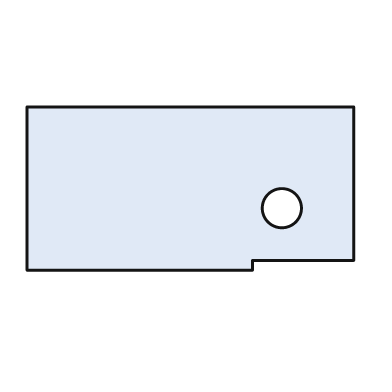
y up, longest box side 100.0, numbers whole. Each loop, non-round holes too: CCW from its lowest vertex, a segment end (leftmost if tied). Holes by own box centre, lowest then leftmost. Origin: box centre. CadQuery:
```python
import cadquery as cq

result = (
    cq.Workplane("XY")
    .moveTo(-50.0, -25.0)
    .lineTo(19.0, -25.0)
    .lineTo(19.0, -22.0)
    .lineTo(50.0, -22.0)
    .lineTo(50.0, 25.0)
    .lineTo(-50.0, 25.0)
    .close()
    .moveTo(28.0, -6.0)
    .circle(6.0)
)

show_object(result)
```